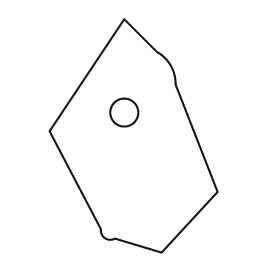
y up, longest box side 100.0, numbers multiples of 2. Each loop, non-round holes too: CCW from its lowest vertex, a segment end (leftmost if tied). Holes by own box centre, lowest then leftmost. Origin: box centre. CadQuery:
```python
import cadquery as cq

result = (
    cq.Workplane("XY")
    .moveTo(12.0, -50.0)
    .lineTo(36.0, -24.0)
    .lineTo(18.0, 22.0)
    .threePointArc((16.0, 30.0), (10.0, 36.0))
    .lineTo(-4.0, 50.0)
    .lineTo(-36.0, 2.0)
    .lineTo(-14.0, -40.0)
    .threePointArc((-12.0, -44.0), (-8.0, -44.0))
    .close()
    .moveTo(-4.0, 10.0)
    .circle(6.0)
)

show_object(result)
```